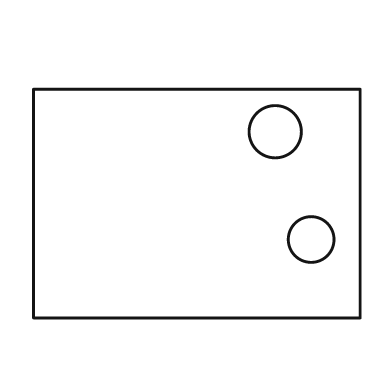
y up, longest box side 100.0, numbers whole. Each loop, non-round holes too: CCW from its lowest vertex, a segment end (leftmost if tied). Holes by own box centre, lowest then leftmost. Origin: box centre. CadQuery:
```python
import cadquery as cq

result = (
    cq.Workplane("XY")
    .moveTo(-50.0, -35.0)
    .lineTo(50.0, -35.0)
    .lineTo(50.0, 35.0)
    .lineTo(-50.0, 35.0)
    .close()
    .moveTo(35.0, -11.0)
    .circle(7.0)
    .moveTo(24.0, 22.0)
    .circle(8.0)
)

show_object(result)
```